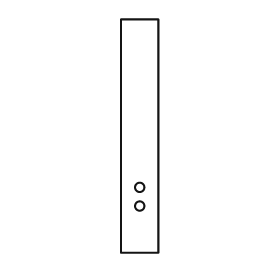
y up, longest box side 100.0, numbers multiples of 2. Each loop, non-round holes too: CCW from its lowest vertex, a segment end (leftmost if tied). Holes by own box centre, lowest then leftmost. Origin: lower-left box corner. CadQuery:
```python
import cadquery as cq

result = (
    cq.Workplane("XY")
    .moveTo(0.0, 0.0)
    .lineTo(16.0, 0.0)
    .lineTo(16.0, 100.0)
    .lineTo(0.0, 100.0)
    .close()
    .moveTo(8.0, 20.0)
    .circle(2.0)
    .moveTo(8.0, 28.0)
    .circle(2.0)
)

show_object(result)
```